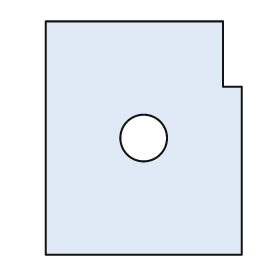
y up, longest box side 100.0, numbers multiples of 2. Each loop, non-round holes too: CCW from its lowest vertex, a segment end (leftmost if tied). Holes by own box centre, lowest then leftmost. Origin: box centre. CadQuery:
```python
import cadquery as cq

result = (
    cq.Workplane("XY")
    .moveTo(-42.0, -50.0)
    .lineTo(42.0, -50.0)
    .lineTo(42.0, 22.0)
    .lineTo(34.0, 22.0)
    .lineTo(34.0, 50.0)
    .lineTo(-42.0, 50.0)
    .close()
    .moveTo(0.0, 0.0)
    .circle(10.0)
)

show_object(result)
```